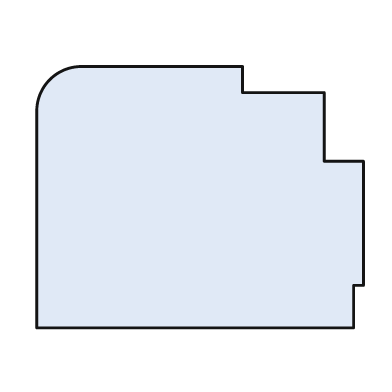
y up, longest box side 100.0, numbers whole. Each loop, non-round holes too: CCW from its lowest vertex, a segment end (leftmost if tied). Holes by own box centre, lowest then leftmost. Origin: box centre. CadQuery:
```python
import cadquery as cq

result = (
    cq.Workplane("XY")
    .moveTo(-50.0, -40.0)
    .lineTo(47.0, -40.0)
    .lineTo(47.0, -27.0)
    .lineTo(50.0, -27.0)
    .lineTo(50.0, 11.0)
    .lineTo(38.0, 11.0)
    .lineTo(38.0, 32.0)
    .lineTo(13.0, 32.0)
    .lineTo(13.0, 40.0)
    .lineTo(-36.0, 40.0)
    .threePointArc((-46.0, 36.0), (-50.0, 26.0))
    .close()
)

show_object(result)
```